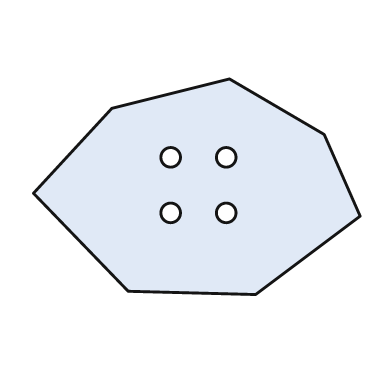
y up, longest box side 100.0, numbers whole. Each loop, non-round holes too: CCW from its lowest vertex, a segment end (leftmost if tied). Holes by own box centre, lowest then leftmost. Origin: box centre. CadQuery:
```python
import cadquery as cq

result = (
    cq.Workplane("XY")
    .moveTo(18.0, -33.0)
    .lineTo(50.0, -9.0)
    .lineTo(39.0, 16.0)
    .lineTo(10.0, 33.0)
    .lineTo(-26.0, 24.0)
    .lineTo(-50.0, -2.0)
    .lineTo(-21.0, -32.0)
    .close()
    .moveTo(-8.0, -8.0)
    .circle(3.0)
    .moveTo(9.0, -8.0)
    .circle(3.0)
    .moveTo(-8.0, 9.0)
    .circle(3.0)
    .moveTo(9.0, 9.0)
    .circle(3.0)
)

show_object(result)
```